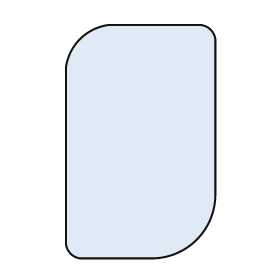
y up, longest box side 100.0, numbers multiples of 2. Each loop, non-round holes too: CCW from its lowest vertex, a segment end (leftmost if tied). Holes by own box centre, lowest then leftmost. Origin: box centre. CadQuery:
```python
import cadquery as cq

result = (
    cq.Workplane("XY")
    .moveTo(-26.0, -50.0)
    .lineTo(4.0, -50.0)
    .threePointArc((24.0, -42.0), (32.0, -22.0))
    .lineTo(32.0, 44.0)
    .threePointArc((30.0, 48.0), (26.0, 50.0))
    .lineTo(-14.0, 50.0)
    .threePointArc((-26.0, 44.0), (-32.0, 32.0))
    .lineTo(-32.0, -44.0)
    .threePointArc((-30.0, -48.0), (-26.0, -50.0))
    .close()
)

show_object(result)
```